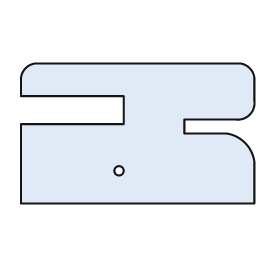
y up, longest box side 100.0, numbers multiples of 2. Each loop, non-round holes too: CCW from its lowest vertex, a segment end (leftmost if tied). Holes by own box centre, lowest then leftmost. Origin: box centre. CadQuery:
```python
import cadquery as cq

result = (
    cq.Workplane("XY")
    .moveTo(-50.0, -30.0)
    .lineTo(50.0, -30.0)
    .lineTo(50.0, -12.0)
    .threePointArc((46.0, -4.0), (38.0, 0.0))
    .lineTo(20.0, 0.0)
    .lineTo(20.0, 6.0)
    .lineTo(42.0, 6.0)
    .threePointArc((48.0, 8.0), (50.0, 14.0))
    .lineTo(50.0, 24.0)
    .threePointArc((48.0, 28.0), (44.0, 30.0))
    .lineTo(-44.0, 30.0)
    .threePointArc((-48.0, 28.0), (-50.0, 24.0))
    .lineTo(-50.0, 16.0)
    .lineTo(-6.0, 16.0)
    .lineTo(-6.0, 4.0)
    .lineTo(-50.0, 4.0)
    .close()
    .moveTo(-8.0, -16.0)
    .circle(2.0)
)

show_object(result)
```